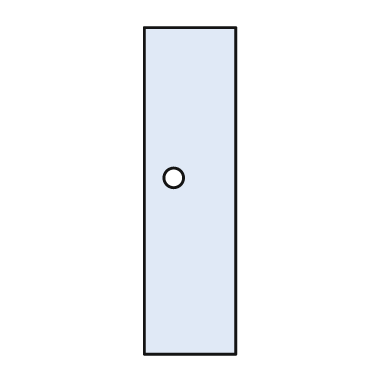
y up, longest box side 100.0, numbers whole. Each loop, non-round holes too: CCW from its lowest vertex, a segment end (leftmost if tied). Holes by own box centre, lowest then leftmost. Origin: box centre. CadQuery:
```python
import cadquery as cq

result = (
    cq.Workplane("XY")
    .moveTo(-14.0, -50.0)
    .lineTo(14.0, -50.0)
    .lineTo(14.0, 50.0)
    .lineTo(-14.0, 50.0)
    .close()
    .moveTo(-5.0, 4.0)
    .circle(3.0)
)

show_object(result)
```